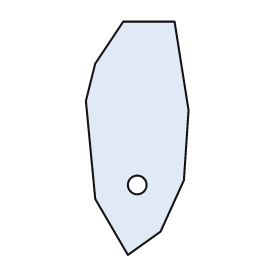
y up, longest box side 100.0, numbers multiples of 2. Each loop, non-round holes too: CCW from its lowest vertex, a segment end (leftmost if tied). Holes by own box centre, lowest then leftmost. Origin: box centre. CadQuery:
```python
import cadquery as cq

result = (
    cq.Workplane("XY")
    .moveTo(-4.0, -50.0)
    .lineTo(10.0, -40.0)
    .lineTo(20.0, -18.0)
    .lineTo(22.0, 12.0)
    .lineTo(16.0, 50.0)
    .lineTo(-6.0, 50.0)
    .lineTo(-18.0, 32.0)
    .lineTo(-22.0, 16.0)
    .lineTo(-18.0, -26.0)
    .close()
    .moveTo(0.0, -20.0)
    .circle(4.0)
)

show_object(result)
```